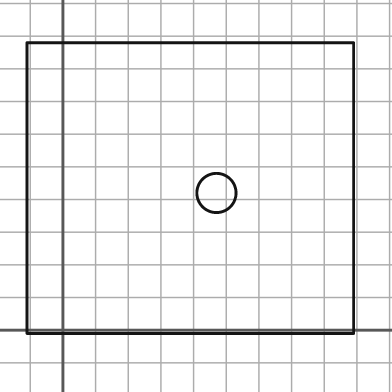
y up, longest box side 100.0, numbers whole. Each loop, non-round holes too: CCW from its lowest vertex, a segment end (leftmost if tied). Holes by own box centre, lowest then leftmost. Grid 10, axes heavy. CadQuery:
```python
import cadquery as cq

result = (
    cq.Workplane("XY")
    .moveTo(-11.0, -1.0)
    .lineTo(89.0, -1.0)
    .lineTo(89.0, 88.0)
    .lineTo(-11.0, 88.0)
    .close()
    .moveTo(47.0, 42.0)
    .circle(6.0)
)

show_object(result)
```